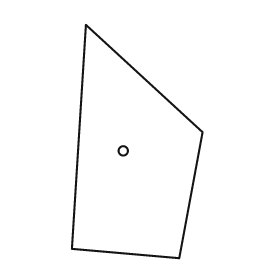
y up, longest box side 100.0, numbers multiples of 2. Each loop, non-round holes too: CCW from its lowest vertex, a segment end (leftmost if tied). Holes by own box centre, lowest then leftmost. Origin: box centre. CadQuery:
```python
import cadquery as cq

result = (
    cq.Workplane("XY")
    .moveTo(18.0, -50.0)
    .lineTo(28.0, 4.0)
    .lineTo(-22.0, 50.0)
    .lineTo(-28.0, -46.0)
    .close()
    .moveTo(-6.0, -4.0)
    .circle(2.0)
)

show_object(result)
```